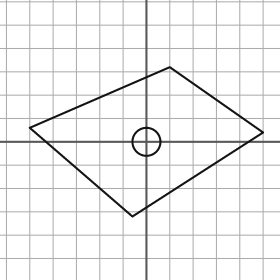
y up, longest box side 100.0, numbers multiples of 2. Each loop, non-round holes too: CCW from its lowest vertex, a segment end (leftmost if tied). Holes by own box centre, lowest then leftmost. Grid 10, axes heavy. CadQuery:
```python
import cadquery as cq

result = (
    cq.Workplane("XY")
    .moveTo(-6.0, -32.0)
    .lineTo(50.0, 4.0)
    .lineTo(10.0, 32.0)
    .lineTo(-50.0, 6.0)
    .close()
    .moveTo(0.0, 0.0)
    .circle(6.0)
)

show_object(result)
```